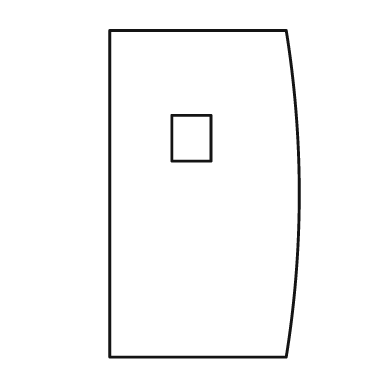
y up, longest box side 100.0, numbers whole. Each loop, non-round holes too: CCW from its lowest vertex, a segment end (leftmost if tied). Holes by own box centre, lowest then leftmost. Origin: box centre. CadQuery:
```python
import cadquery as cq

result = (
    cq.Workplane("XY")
    .moveTo(-29.0, -50.0)
    .lineTo(25.0, -50.0)
    .threePointArc((29.0, 0.0), (25.0, 50.0))
    .lineTo(-29.0, 50.0)
    .close()
    .moveTo(-10.0, 10.0)
    .lineTo(2.0, 10.0)
    .lineTo(2.0, 24.0)
    .lineTo(-10.0, 24.0)
    .close()
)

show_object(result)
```